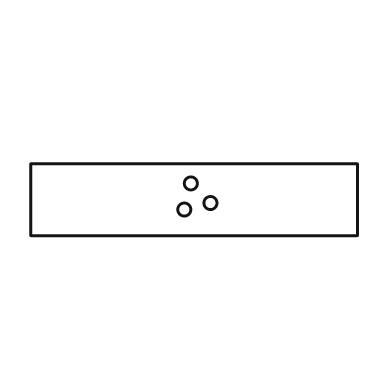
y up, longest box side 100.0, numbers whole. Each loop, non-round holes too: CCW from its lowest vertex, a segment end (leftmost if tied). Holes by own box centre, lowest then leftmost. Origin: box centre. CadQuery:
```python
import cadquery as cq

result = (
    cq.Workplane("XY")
    .moveTo(-50.0, -11.0)
    .lineTo(50.0, -11.0)
    .lineTo(50.0, 11.0)
    .lineTo(-50.0, 11.0)
    .close()
    .moveTo(-3.0, -3.0)
    .circle(2.0)
    .moveTo(5.0, -1.0)
    .circle(2.0)
    .moveTo(-1.0, 5.0)
    .circle(2.0)
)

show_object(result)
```